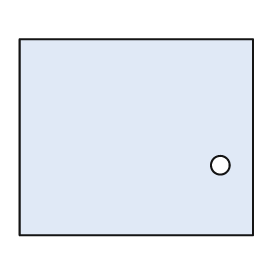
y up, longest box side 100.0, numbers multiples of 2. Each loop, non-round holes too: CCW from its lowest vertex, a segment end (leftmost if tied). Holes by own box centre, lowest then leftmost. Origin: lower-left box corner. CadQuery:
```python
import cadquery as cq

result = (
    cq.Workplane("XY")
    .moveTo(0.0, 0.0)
    .lineTo(100.0, 0.0)
    .lineTo(100.0, 84.0)
    .lineTo(0.0, 84.0)
    .close()
    .moveTo(86.0, 30.0)
    .circle(4.0)
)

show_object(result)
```